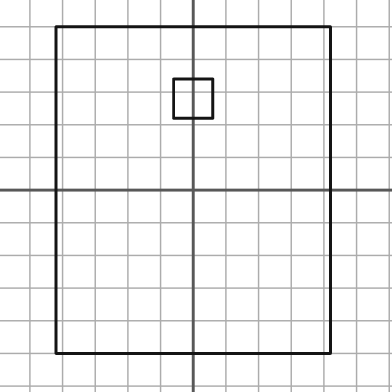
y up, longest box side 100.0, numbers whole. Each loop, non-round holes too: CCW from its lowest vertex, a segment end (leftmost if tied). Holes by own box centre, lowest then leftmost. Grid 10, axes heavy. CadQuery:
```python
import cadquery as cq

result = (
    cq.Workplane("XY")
    .moveTo(-42.0, -50.0)
    .lineTo(42.0, -50.0)
    .lineTo(42.0, 50.0)
    .lineTo(-42.0, 50.0)
    .close()
    .moveTo(-6.0, 22.0)
    .lineTo(6.0, 22.0)
    .lineTo(6.0, 34.0)
    .lineTo(-6.0, 34.0)
    .close()
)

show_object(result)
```